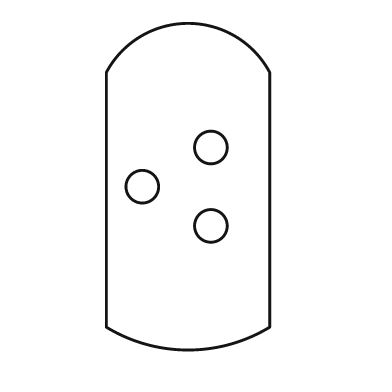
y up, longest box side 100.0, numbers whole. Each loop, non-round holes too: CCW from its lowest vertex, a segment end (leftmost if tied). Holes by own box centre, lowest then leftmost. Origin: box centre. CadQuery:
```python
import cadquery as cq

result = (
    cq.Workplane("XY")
    .moveTo(-25.0, -43.0)
    .threePointArc((0.0, -50.0), (25.0, -43.0))
    .lineTo(25.0, 35.0)
    .threePointArc((0.0, 50.0), (-25.0, 35.0))
    .close()
    .moveTo(7.0, -12.0)
    .circle(5.0)
    .moveTo(-14.0, 0.0)
    .circle(5.0)
    .moveTo(7.0, 12.0)
    .circle(5.0)
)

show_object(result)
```